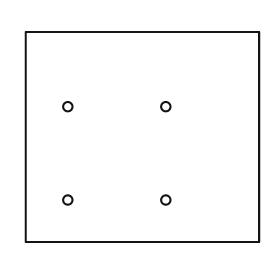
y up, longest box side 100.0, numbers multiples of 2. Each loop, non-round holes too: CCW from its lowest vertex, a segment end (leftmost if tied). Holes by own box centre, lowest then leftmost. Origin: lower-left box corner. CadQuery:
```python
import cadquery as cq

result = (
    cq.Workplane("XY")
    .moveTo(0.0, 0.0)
    .lineTo(100.0, 0.0)
    .lineTo(100.0, 90.0)
    .lineTo(0.0, 90.0)
    .close()
    .moveTo(18.0, 18.0)
    .circle(2.0)
    .moveTo(60.0, 18.0)
    .circle(2.0)
    .moveTo(18.0, 58.0)
    .circle(2.0)
    .moveTo(60.0, 58.0)
    .circle(2.0)
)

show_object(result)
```